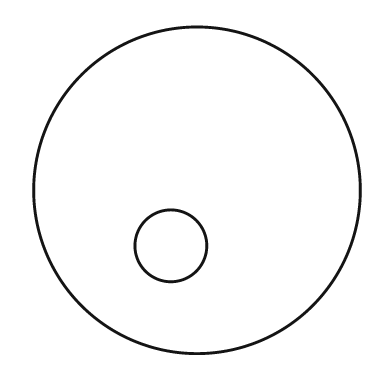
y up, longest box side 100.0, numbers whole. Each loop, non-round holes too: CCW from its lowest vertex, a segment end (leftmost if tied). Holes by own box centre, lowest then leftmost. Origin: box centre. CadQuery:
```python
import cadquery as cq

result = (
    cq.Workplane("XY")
    .moveTo(0.0, 0.0)
    .circle(50.0)
    .moveTo(-8.0, -17.0)
    .circle(11.0)
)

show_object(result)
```